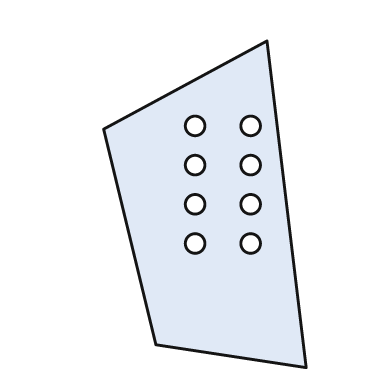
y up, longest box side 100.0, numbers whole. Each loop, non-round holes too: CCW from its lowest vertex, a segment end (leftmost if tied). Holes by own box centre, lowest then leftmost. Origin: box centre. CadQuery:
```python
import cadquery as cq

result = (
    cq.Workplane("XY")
    .moveTo(31.0, -50.0)
    .lineTo(19.0, 50.0)
    .lineTo(-31.0, 23.0)
    .lineTo(-15.0, -43.0)
    .close()
    .moveTo(-3.0, -12.0)
    .circle(3.0)
    .moveTo(14.0, -12.0)
    .circle(3.0)
    .moveTo(-3.0, 0.0)
    .circle(3.0)
    .moveTo(14.0, 0.0)
    .circle(3.0)
    .moveTo(-3.0, 12.0)
    .circle(3.0)
    .moveTo(14.0, 12.0)
    .circle(3.0)
    .moveTo(-3.0, 24.0)
    .circle(3.0)
    .moveTo(14.0, 24.0)
    .circle(3.0)
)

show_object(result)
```